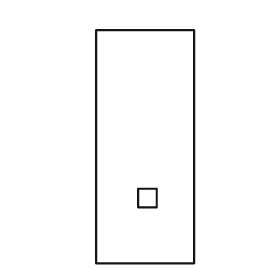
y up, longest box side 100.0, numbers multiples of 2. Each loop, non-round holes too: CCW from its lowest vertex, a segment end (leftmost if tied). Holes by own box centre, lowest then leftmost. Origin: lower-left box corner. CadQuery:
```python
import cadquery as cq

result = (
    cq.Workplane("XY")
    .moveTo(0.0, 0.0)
    .lineTo(42.0, 0.0)
    .lineTo(42.0, 100.0)
    .lineTo(0.0, 100.0)
    .close()
    .moveTo(18.0, 24.0)
    .lineTo(26.0, 24.0)
    .lineTo(26.0, 32.0)
    .lineTo(18.0, 32.0)
    .close()
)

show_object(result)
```